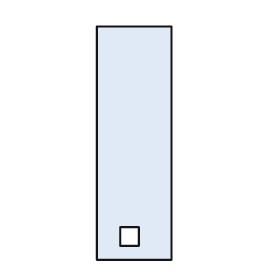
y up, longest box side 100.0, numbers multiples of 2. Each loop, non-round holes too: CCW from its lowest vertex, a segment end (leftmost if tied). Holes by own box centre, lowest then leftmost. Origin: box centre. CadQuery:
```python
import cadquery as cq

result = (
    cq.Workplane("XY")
    .moveTo(-16.0, -50.0)
    .lineTo(16.0, -50.0)
    .lineTo(16.0, 50.0)
    .lineTo(-16.0, 50.0)
    .close()
    .moveTo(-6.0, -44.0)
    .lineTo(2.0, -44.0)
    .lineTo(2.0, -36.0)
    .lineTo(-6.0, -36.0)
    .close()
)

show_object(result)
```